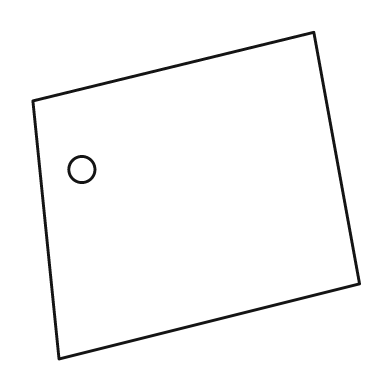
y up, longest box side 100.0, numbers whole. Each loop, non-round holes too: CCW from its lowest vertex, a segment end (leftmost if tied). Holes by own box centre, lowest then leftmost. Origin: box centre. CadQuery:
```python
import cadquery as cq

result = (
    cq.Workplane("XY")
    .moveTo(-42.0, -50.0)
    .lineTo(50.0, -27.0)
    .lineTo(36.0, 50.0)
    .lineTo(-50.0, 29.0)
    .close()
    .moveTo(-35.0, 8.0)
    .circle(4.0)
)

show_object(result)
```